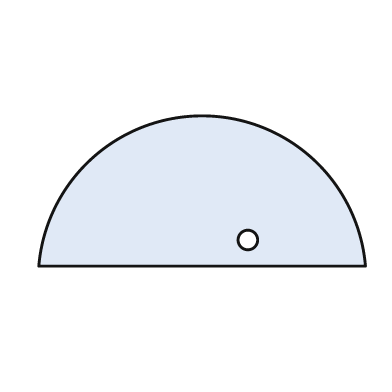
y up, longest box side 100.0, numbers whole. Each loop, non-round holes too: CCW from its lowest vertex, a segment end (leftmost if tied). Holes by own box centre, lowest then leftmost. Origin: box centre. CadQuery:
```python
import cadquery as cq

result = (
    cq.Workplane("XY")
    .moveTo(-50.0, -23.0)
    .lineTo(50.0, -23.0)
    .threePointArc((0.0, 23.0), (-50.0, -23.0))
    .close()
    .moveTo(14.0, -15.0)
    .circle(3.0)
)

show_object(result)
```